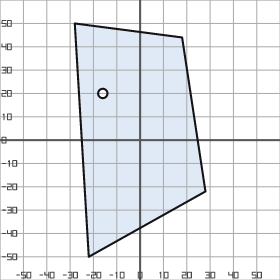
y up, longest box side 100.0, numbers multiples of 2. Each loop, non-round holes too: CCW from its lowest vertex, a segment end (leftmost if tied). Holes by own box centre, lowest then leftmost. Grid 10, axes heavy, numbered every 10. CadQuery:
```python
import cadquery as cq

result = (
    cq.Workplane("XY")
    .moveTo(-22.0, -50.0)
    .lineTo(28.0, -22.0)
    .lineTo(18.0, 44.0)
    .lineTo(-28.0, 50.0)
    .close()
    .moveTo(-16.0, 20.0)
    .circle(2.0)
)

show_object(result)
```